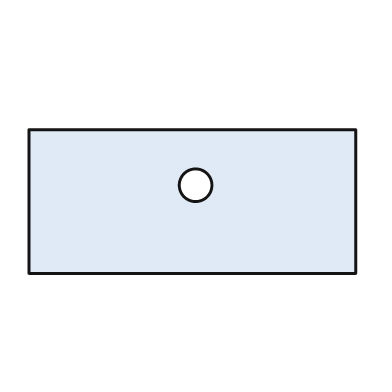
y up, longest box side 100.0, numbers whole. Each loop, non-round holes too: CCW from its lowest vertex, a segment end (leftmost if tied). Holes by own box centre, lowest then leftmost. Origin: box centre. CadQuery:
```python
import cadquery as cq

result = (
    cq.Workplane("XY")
    .moveTo(-50.0, -22.0)
    .lineTo(50.0, -22.0)
    .lineTo(50.0, 22.0)
    .lineTo(-50.0, 22.0)
    .close()
    .moveTo(1.0, 5.0)
    .circle(5.0)
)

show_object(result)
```